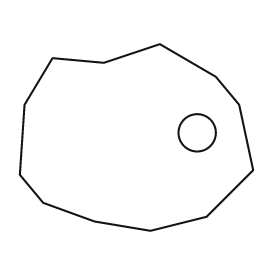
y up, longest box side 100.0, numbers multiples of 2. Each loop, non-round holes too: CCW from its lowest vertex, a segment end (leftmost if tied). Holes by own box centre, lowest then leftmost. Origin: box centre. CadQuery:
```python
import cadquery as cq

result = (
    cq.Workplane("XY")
    .moveTo(6.0, -40.0)
    .lineTo(30.0, -34.0)
    .lineTo(50.0, -14.0)
    .lineTo(44.0, 14.0)
    .lineTo(34.0, 26.0)
    .lineTo(10.0, 40.0)
    .lineTo(-14.0, 32.0)
    .lineTo(-36.0, 34.0)
    .lineTo(-48.0, 14.0)
    .lineTo(-50.0, -16.0)
    .lineTo(-40.0, -28.0)
    .lineTo(-18.0, -36.0)
    .close()
    .moveTo(26.0, 2.0)
    .circle(8.0)
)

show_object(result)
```